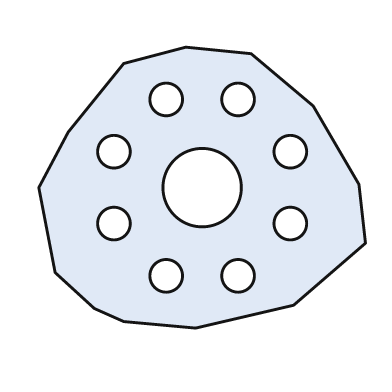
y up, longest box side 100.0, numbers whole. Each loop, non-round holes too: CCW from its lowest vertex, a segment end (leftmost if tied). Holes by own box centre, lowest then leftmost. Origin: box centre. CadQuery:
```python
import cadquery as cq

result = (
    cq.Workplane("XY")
    .moveTo(-2.0, -43.0)
    .lineTo(28.0, -36.0)
    .lineTo(50.0, -17.0)
    .lineTo(48.0, 1.0)
    .lineTo(34.0, 25.0)
    .lineTo(15.0, 41.0)
    .lineTo(-5.0, 43.0)
    .lineTo(-24.0, 38.0)
    .lineTo(-41.0, 17.0)
    .lineTo(-50.0, 0.0)
    .lineTo(-45.0, -26.0)
    .lineTo(-33.0, -37.0)
    .lineTo(-24.0, -41.0)
    .close()
    .moveTo(-11.0, -27.0)
    .circle(5.0)
    .moveTo(11.0, -27.0)
    .circle(5.0)
    .moveTo(-27.0, -11.0)
    .circle(5.0)
    .moveTo(27.0, -11.0)
    .circle(5.0)
    .moveTo(0.0, 0.0)
    .circle(12.0)
    .moveTo(-27.0, 11.0)
    .circle(5.0)
    .moveTo(27.0, 11.0)
    .circle(5.0)
    .moveTo(-11.0, 27.0)
    .circle(5.0)
    .moveTo(11.0, 27.0)
    .circle(5.0)
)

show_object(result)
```